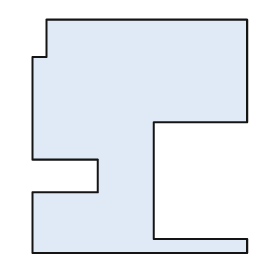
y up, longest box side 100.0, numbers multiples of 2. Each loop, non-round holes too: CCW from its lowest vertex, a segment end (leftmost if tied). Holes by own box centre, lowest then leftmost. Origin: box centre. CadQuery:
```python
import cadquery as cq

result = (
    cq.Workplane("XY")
    .moveTo(-46.0, -50.0)
    .lineTo(46.0, -50.0)
    .lineTo(46.0, -44.0)
    .lineTo(6.0, -44.0)
    .lineTo(6.0, 6.0)
    .lineTo(46.0, 6.0)
    .lineTo(46.0, 50.0)
    .lineTo(-40.0, 50.0)
    .lineTo(-40.0, 34.0)
    .lineTo(-46.0, 34.0)
    .lineTo(-46.0, -10.0)
    .lineTo(-18.0, -10.0)
    .lineTo(-18.0, -24.0)
    .lineTo(-46.0, -24.0)
    .close()
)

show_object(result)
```